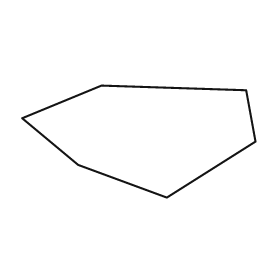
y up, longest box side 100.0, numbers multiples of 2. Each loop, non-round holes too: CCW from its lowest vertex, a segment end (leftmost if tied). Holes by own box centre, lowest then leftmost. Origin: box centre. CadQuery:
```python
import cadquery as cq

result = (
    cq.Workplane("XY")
    .moveTo(12.0, -24.0)
    .lineTo(50.0, 0.0)
    .lineTo(46.0, 22.0)
    .lineTo(-16.0, 24.0)
    .lineTo(-50.0, 10.0)
    .lineTo(-26.0, -10.0)
    .close()
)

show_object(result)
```